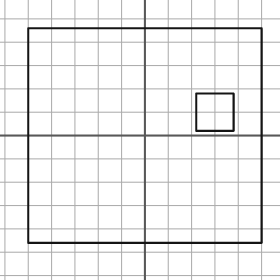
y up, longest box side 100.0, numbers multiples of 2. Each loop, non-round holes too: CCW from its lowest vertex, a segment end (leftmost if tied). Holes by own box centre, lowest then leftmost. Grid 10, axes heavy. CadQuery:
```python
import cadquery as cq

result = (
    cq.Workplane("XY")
    .moveTo(-50.0, -46.0)
    .lineTo(50.0, -46.0)
    .lineTo(50.0, 46.0)
    .lineTo(-50.0, 46.0)
    .close()
    .moveTo(22.0, 2.0)
    .lineTo(38.0, 2.0)
    .lineTo(38.0, 18.0)
    .lineTo(22.0, 18.0)
    .close()
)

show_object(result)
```